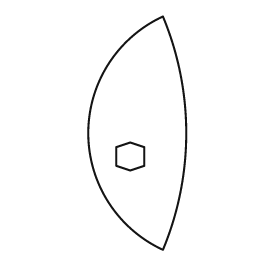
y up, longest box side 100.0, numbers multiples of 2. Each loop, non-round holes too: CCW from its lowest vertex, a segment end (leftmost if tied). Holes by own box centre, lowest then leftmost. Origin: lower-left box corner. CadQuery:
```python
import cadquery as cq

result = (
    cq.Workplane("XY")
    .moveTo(32.0, 0.0)
    .threePointArc((42.0, 50.0), (32.0, 100.0))
    .threePointArc((0.0, 50.0), (32.0, 0.0))
    .close()
    .moveTo(18.0, 34.0)
    .lineTo(24.0, 36.0)
    .lineTo(24.0, 44.0)
    .lineTo(18.0, 46.0)
    .lineTo(12.0, 44.0)
    .lineTo(12.0, 36.0)
    .close()
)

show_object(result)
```